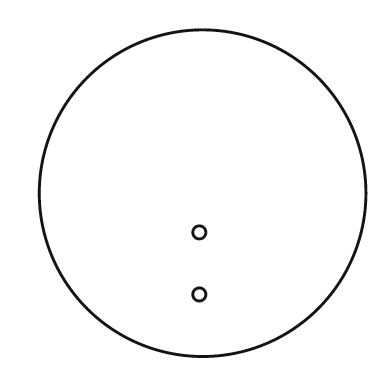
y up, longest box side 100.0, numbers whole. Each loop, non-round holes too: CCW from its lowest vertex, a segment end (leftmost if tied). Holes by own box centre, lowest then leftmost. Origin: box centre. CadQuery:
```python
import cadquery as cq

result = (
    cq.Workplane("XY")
    .moveTo(0.0, 0.0)
    .circle(50.0)
    .moveTo(-1.0, -31.0)
    .circle(2.0)
    .moveTo(-1.0, -12.0)
    .circle(2.0)
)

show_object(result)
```